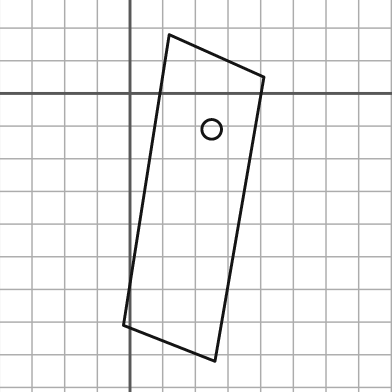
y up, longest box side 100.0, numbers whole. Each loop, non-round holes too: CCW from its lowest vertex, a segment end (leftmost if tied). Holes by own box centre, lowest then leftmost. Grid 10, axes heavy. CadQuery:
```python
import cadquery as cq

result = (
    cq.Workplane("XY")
    .moveTo(26.0, -82.0)
    .lineTo(41.0, 5.0)
    .lineTo(12.0, 18.0)
    .lineTo(-2.0, -71.0)
    .close()
    .moveTo(25.0, -11.0)
    .circle(3.0)
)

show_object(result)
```